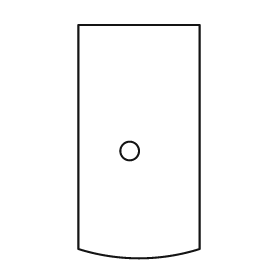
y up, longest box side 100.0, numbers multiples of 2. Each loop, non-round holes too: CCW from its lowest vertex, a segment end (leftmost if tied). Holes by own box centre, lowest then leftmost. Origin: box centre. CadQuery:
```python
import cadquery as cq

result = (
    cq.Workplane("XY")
    .moveTo(-26.0, -46.0)
    .threePointArc((0.0, -50.0), (26.0, -46.0))
    .lineTo(26.0, 50.0)
    .lineTo(-26.0, 50.0)
    .close()
    .moveTo(-4.0, -4.0)
    .circle(4.0)
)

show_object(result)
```